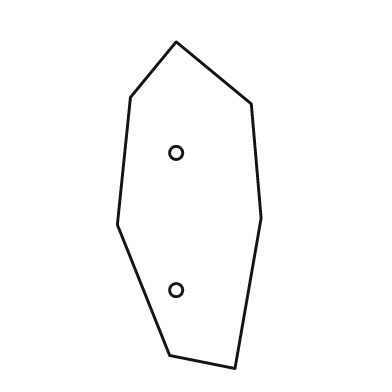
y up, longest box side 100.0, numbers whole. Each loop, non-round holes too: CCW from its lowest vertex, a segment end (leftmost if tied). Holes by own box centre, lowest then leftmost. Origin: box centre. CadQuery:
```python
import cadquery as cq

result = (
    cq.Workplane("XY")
    .moveTo(14.0, -50.0)
    .lineTo(22.0, -4.0)
    .lineTo(19.0, 31.0)
    .lineTo(-4.0, 50.0)
    .lineTo(-18.0, 33.0)
    .lineTo(-22.0, -6.0)
    .lineTo(-6.0, -46.0)
    .close()
    .moveTo(-4.0, -26.0)
    .circle(2.0)
    .moveTo(-4.0, 16.0)
    .circle(2.0)
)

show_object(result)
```